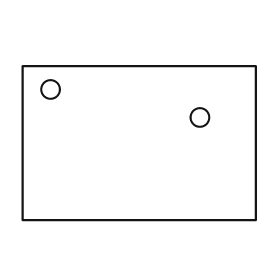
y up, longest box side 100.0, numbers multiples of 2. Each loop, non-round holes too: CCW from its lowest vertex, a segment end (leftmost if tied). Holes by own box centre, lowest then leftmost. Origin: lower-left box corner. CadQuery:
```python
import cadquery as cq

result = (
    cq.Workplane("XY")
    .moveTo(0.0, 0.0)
    .lineTo(100.0, 0.0)
    .lineTo(100.0, 66.0)
    .lineTo(0.0, 66.0)
    .close()
    .moveTo(76.0, 44.0)
    .circle(4.0)
    .moveTo(12.0, 56.0)
    .circle(4.0)
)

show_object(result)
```